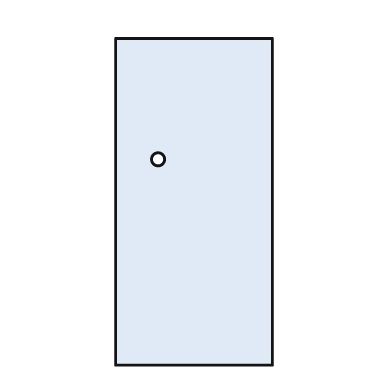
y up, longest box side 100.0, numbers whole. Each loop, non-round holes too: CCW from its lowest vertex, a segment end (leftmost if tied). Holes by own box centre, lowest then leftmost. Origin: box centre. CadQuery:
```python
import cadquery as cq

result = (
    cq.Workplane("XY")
    .moveTo(-24.0, -50.0)
    .lineTo(24.0, -50.0)
    .lineTo(24.0, 50.0)
    .lineTo(-24.0, 50.0)
    .close()
    .moveTo(-11.0, 13.0)
    .circle(2.0)
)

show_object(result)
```